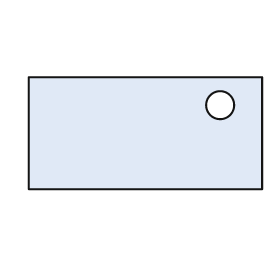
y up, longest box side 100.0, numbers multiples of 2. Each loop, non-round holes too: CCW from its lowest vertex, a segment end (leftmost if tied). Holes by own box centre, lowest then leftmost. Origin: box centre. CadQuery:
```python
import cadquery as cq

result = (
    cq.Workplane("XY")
    .moveTo(-50.0, -24.0)
    .lineTo(50.0, -24.0)
    .lineTo(50.0, 24.0)
    .lineTo(-50.0, 24.0)
    .close()
    .moveTo(32.0, 12.0)
    .circle(6.0)
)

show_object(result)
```